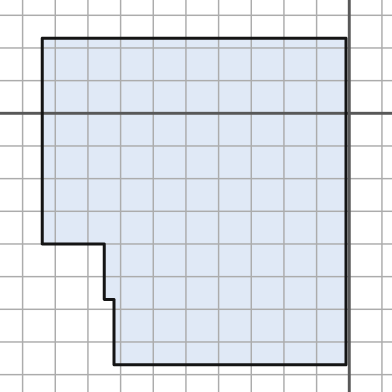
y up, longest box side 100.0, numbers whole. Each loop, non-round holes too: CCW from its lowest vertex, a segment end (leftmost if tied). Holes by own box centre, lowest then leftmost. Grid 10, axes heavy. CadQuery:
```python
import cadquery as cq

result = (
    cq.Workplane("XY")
    .moveTo(-72.0, -77.0)
    .lineTo(-1.0, -77.0)
    .lineTo(-1.0, 23.0)
    .lineTo(-94.0, 23.0)
    .lineTo(-94.0, -40.0)
    .lineTo(-75.0, -40.0)
    .lineTo(-75.0, -57.0)
    .lineTo(-72.0, -57.0)
    .close()
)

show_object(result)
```